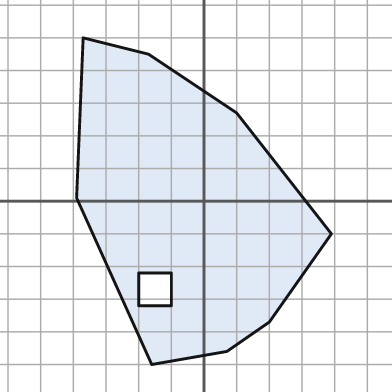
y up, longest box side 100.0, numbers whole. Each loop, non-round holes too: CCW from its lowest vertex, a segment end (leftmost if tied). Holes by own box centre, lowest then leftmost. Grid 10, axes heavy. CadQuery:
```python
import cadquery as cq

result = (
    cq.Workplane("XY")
    .moveTo(-16.0, -50.0)
    .lineTo(7.0, -46.0)
    .lineTo(20.0, -37.0)
    .lineTo(39.0, -10.0)
    .lineTo(10.0, 27.0)
    .lineTo(-17.0, 45.0)
    .lineTo(-37.0, 50.0)
    .lineTo(-39.0, 1.0)
    .close()
    .moveTo(-20.0, -32.0)
    .lineTo(-10.0, -32.0)
    .lineTo(-10.0, -22.0)
    .lineTo(-20.0, -22.0)
    .close()
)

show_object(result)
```